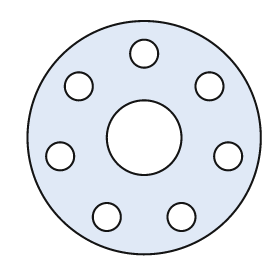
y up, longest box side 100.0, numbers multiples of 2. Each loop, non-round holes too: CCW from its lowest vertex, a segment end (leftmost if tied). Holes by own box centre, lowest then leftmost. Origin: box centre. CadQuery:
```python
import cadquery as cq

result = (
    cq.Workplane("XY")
    .moveTo(0.0, 0.0)
    .circle(50.0)
    .moveTo(-16.0, -34.0)
    .circle(6.0)
    .moveTo(16.0, -34.0)
    .circle(6.0)
    .moveTo(-36.0, -8.0)
    .circle(6.0)
    .moveTo(36.0, -8.0)
    .circle(6.0)
    .moveTo(0.0, 0.0)
    .circle(16.0)
    .moveTo(-28.0, 22.0)
    .circle(6.0)
    .moveTo(28.0, 22.0)
    .circle(6.0)
    .moveTo(0.0, 36.0)
    .circle(6.0)
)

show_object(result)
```